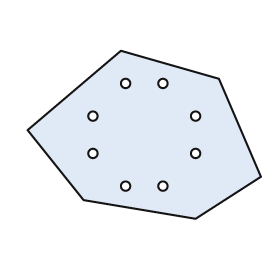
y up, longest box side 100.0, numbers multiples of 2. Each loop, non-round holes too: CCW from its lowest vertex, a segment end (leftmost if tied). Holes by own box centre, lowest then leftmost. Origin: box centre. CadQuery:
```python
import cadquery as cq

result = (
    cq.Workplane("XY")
    .moveTo(22.0, -36.0)
    .lineTo(50.0, -18.0)
    .lineTo(32.0, 24.0)
    .lineTo(-10.0, 36.0)
    .lineTo(-50.0, 2.0)
    .lineTo(-26.0, -28.0)
    .close()
    .moveTo(-8.0, -22.0)
    .circle(2.0)
    .moveTo(8.0, -22.0)
    .circle(2.0)
    .moveTo(-22.0, -8.0)
    .circle(2.0)
    .moveTo(22.0, -8.0)
    .circle(2.0)
    .moveTo(-22.0, 8.0)
    .circle(2.0)
    .moveTo(22.0, 8.0)
    .circle(2.0)
    .moveTo(-8.0, 22.0)
    .circle(2.0)
    .moveTo(8.0, 22.0)
    .circle(2.0)
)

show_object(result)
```